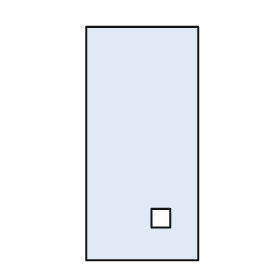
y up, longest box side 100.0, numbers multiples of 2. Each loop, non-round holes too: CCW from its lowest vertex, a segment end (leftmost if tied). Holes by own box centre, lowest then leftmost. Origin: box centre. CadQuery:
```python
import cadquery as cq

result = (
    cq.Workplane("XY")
    .moveTo(-24.0, -50.0)
    .lineTo(24.0, -50.0)
    .lineTo(24.0, 50.0)
    .lineTo(-24.0, 50.0)
    .close()
    .moveTo(4.0, -36.0)
    .lineTo(12.0, -36.0)
    .lineTo(12.0, -28.0)
    .lineTo(4.0, -28.0)
    .close()
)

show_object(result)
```